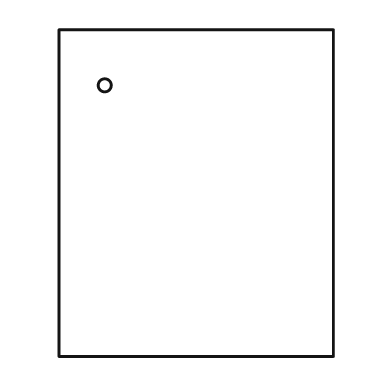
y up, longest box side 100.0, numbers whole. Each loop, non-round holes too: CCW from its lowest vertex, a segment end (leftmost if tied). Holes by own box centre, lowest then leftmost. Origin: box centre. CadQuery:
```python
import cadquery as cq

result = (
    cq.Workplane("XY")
    .moveTo(-42.0, -50.0)
    .lineTo(42.0, -50.0)
    .lineTo(42.0, 50.0)
    .lineTo(-42.0, 50.0)
    .close()
    .moveTo(-28.0, 33.0)
    .circle(2.0)
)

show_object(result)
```